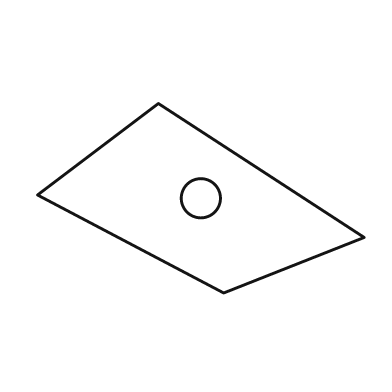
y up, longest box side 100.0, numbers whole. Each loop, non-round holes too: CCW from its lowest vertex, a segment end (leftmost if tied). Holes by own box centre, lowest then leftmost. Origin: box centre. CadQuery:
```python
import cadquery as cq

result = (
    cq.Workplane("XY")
    .moveTo(7.0, -29.0)
    .lineTo(50.0, -12.0)
    .lineTo(-13.0, 29.0)
    .lineTo(-50.0, 1.0)
    .close()
    .moveTo(0.0, 0.0)
    .circle(6.0)
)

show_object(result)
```